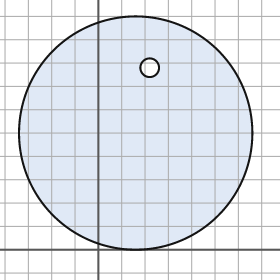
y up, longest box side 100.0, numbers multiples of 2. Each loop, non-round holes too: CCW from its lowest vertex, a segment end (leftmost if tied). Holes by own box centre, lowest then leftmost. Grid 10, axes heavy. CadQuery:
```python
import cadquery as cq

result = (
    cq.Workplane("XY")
    .moveTo(16.0, 50.0)
    .circle(50.0)
    .moveTo(22.0, 78.0)
    .circle(4.0)
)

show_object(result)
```